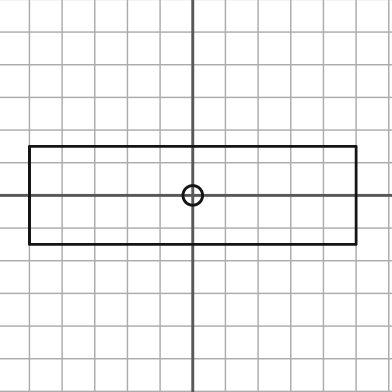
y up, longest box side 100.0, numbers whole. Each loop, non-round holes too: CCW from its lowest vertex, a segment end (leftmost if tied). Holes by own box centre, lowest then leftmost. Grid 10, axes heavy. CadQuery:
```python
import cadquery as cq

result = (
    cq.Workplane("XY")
    .moveTo(-50.0, -15.0)
    .lineTo(50.0, -15.0)
    .lineTo(50.0, 15.0)
    .lineTo(-50.0, 15.0)
    .close()
    .moveTo(0.0, 0.0)
    .circle(3.0)
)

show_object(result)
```